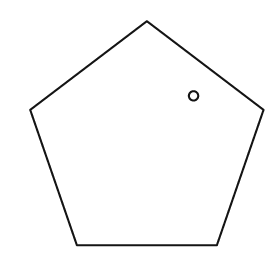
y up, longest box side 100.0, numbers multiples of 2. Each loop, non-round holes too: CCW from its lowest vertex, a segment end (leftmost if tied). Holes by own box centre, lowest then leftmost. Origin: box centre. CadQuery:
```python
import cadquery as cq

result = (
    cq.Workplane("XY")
    .moveTo(-30.0, -48.0)
    .lineTo(30.0, -48.0)
    .lineTo(50.0, 10.0)
    .lineTo(0.0, 48.0)
    .lineTo(-50.0, 10.0)
    .close()
    .moveTo(20.0, 16.0)
    .circle(2.0)
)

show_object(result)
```